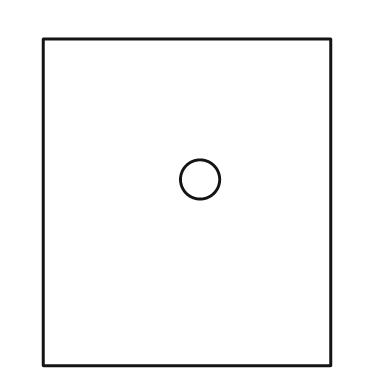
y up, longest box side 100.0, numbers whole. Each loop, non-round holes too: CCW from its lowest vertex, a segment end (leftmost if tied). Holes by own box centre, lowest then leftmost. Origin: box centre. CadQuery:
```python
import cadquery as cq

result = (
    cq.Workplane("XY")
    .moveTo(-44.0, -50.0)
    .lineTo(44.0, -50.0)
    .lineTo(44.0, 50.0)
    .lineTo(-44.0, 50.0)
    .close()
    .moveTo(4.0, 7.0)
    .circle(6.0)
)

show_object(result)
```